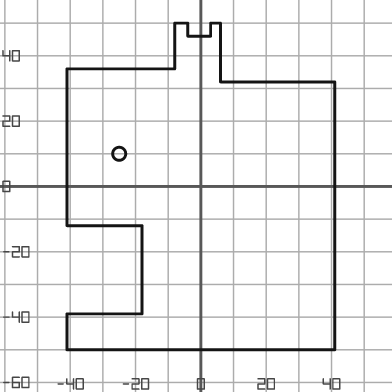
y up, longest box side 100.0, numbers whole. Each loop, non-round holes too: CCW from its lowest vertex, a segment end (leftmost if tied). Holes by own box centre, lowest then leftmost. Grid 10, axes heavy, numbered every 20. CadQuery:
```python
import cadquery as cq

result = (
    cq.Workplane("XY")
    .moveTo(-41.0, -50.0)
    .lineTo(41.0, -50.0)
    .lineTo(41.0, 32.0)
    .lineTo(6.0, 32.0)
    .lineTo(6.0, 50.0)
    .lineTo(3.0, 50.0)
    .lineTo(3.0, 46.0)
    .lineTo(-4.0, 46.0)
    .lineTo(-4.0, 50.0)
    .lineTo(-8.0, 50.0)
    .lineTo(-8.0, 36.0)
    .lineTo(-41.0, 36.0)
    .lineTo(-41.0, -12.0)
    .lineTo(-18.0, -12.0)
    .lineTo(-18.0, -39.0)
    .lineTo(-41.0, -39.0)
    .close()
    .moveTo(-25.0, 10.0)
    .circle(2.0)
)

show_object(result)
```